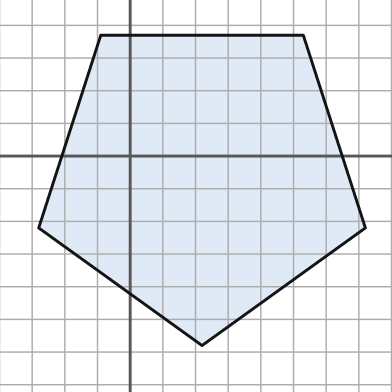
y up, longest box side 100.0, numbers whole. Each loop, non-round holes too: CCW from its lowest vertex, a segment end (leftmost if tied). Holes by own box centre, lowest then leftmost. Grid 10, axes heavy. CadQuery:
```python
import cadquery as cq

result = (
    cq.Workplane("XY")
    .moveTo(22.0, -58.0)
    .lineTo(72.0, -22.0)
    .lineTo(53.0, 37.0)
    .lineTo(-9.0, 37.0)
    .lineTo(-28.0, -22.0)
    .close()
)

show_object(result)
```